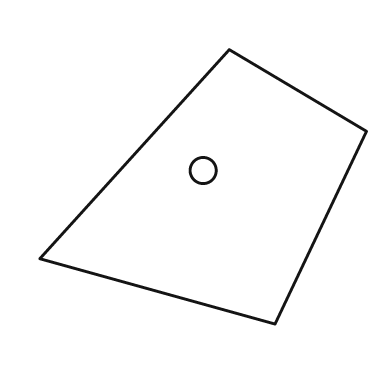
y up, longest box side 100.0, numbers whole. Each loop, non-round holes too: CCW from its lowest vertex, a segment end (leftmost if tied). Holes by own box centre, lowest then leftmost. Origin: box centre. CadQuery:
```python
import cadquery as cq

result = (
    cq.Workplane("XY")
    .moveTo(22.0, -42.0)
    .lineTo(50.0, 17.0)
    .lineTo(8.0, 42.0)
    .lineTo(-50.0, -22.0)
    .close()
    .moveTo(0.0, 5.0)
    .circle(4.0)
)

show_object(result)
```